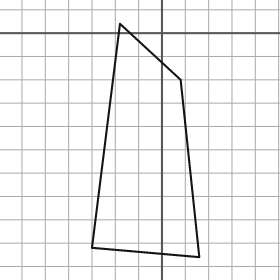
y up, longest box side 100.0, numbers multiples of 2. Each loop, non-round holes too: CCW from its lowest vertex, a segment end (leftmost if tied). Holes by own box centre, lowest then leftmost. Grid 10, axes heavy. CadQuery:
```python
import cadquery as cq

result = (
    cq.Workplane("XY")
    .moveTo(16.0, -96.0)
    .lineTo(8.0, -20.0)
    .lineTo(-18.0, 4.0)
    .lineTo(-30.0, -92.0)
    .close()
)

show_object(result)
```